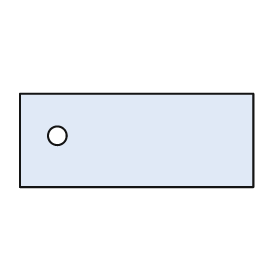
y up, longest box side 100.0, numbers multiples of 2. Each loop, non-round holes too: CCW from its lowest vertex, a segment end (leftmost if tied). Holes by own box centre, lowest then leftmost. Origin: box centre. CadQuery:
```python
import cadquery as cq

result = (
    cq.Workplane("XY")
    .moveTo(-50.0, -20.0)
    .lineTo(50.0, -20.0)
    .lineTo(50.0, 20.0)
    .lineTo(-50.0, 20.0)
    .close()
    .moveTo(-34.0, 2.0)
    .circle(4.0)
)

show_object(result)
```